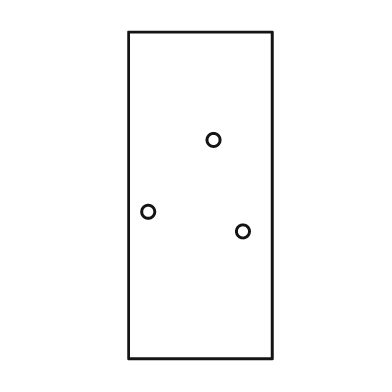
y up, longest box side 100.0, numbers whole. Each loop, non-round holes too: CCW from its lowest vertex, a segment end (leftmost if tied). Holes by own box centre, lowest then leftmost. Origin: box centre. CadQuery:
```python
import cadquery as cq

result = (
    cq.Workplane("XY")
    .moveTo(-22.0, -50.0)
    .lineTo(22.0, -50.0)
    .lineTo(22.0, 50.0)
    .lineTo(-22.0, 50.0)
    .close()
    .moveTo(13.0, -11.0)
    .circle(2.0)
    .moveTo(-16.0, -5.0)
    .circle(2.0)
    .moveTo(4.0, 17.0)
    .circle(2.0)
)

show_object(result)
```